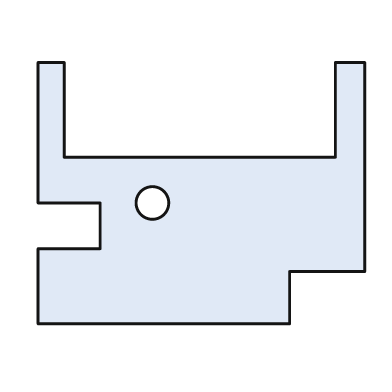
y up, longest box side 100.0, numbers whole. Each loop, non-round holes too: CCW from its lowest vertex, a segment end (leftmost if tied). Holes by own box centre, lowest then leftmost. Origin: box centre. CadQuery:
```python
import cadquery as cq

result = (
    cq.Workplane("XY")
    .moveTo(-50.0, -40.0)
    .lineTo(27.0, -40.0)
    .lineTo(27.0, -24.0)
    .lineTo(50.0, -24.0)
    .lineTo(50.0, 40.0)
    .lineTo(41.0, 40.0)
    .lineTo(41.0, 11.0)
    .lineTo(-42.0, 11.0)
    .lineTo(-42.0, 40.0)
    .lineTo(-50.0, 40.0)
    .lineTo(-50.0, -3.0)
    .lineTo(-31.0, -3.0)
    .lineTo(-31.0, -17.0)
    .lineTo(-50.0, -17.0)
    .close()
    .moveTo(-15.0, -3.0)
    .circle(5.0)
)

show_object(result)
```